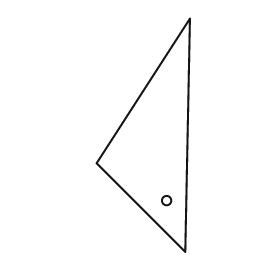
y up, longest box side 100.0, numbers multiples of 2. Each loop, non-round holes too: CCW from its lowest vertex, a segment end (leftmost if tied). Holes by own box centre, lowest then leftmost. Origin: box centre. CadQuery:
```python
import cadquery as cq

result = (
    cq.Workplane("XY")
    .moveTo(18.0, -50.0)
    .lineTo(20.0, 50.0)
    .lineTo(-20.0, -12.0)
    .close()
    .moveTo(10.0, -28.0)
    .circle(2.0)
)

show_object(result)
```